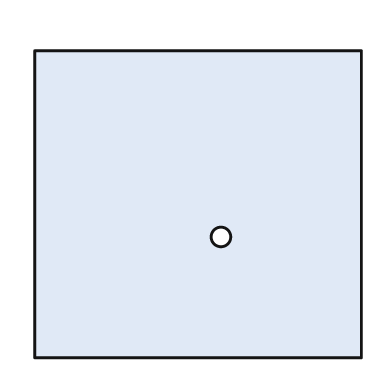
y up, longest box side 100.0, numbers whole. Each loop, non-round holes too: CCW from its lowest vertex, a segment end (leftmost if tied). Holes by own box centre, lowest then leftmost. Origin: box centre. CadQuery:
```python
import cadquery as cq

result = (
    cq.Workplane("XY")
    .moveTo(-50.0, -47.0)
    .lineTo(50.0, -47.0)
    .lineTo(50.0, 47.0)
    .lineTo(-50.0, 47.0)
    .close()
    .moveTo(7.0, -10.0)
    .circle(3.0)
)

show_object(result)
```